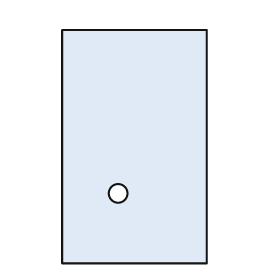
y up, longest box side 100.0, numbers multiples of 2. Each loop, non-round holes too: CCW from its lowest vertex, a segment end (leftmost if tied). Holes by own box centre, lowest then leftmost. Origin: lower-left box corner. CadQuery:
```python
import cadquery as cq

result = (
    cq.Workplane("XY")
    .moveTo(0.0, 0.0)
    .lineTo(62.0, 0.0)
    .lineTo(62.0, 100.0)
    .lineTo(0.0, 100.0)
    .close()
    .moveTo(24.0, 30.0)
    .circle(4.0)
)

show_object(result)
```